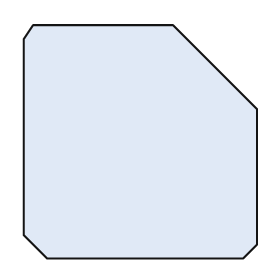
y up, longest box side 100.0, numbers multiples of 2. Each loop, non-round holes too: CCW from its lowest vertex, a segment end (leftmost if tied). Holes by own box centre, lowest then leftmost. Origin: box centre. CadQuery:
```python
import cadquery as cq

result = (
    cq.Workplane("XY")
    .moveTo(-40.0, -50.0)
    .lineTo(44.0, -50.0)
    .lineTo(50.0, -44.0)
    .lineTo(50.0, 14.0)
    .lineTo(14.0, 50.0)
    .lineTo(-46.0, 50.0)
    .lineTo(-50.0, 44.0)
    .lineTo(-50.0, -40.0)
    .close()
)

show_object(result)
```